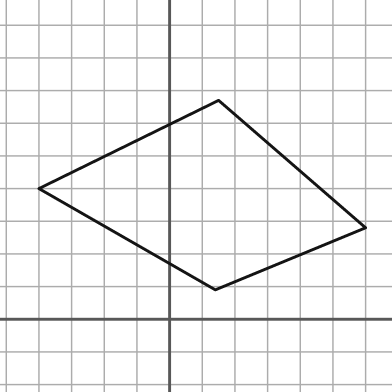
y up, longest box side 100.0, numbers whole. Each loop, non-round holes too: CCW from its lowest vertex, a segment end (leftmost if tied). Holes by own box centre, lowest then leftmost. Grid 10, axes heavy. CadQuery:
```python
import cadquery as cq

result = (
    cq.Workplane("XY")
    .moveTo(14.0, 9.0)
    .lineTo(60.0, 28.0)
    .lineTo(15.0, 67.0)
    .lineTo(-40.0, 40.0)
    .close()
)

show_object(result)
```